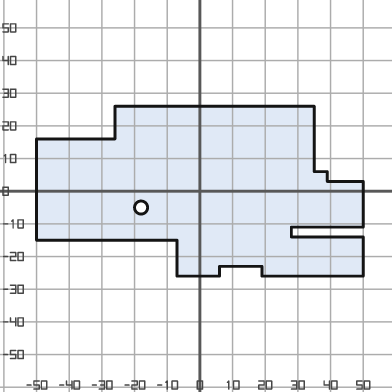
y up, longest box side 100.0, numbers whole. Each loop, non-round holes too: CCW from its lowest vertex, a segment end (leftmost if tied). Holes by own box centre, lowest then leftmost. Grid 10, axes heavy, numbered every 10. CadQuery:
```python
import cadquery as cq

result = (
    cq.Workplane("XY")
    .moveTo(-7.0, -26.0)
    .lineTo(6.0, -26.0)
    .lineTo(6.0, -23.0)
    .lineTo(19.0, -23.0)
    .lineTo(19.0, -26.0)
    .lineTo(50.0, -26.0)
    .lineTo(50.0, -14.0)
    .lineTo(28.0, -14.0)
    .lineTo(28.0, -11.0)
    .lineTo(50.0, -11.0)
    .lineTo(50.0, 3.0)
    .lineTo(39.0, 3.0)
    .lineTo(39.0, 6.0)
    .lineTo(35.0, 6.0)
    .lineTo(35.0, 26.0)
    .lineTo(-26.0, 26.0)
    .lineTo(-26.0, 16.0)
    .lineTo(-50.0, 16.0)
    .lineTo(-50.0, -15.0)
    .lineTo(-7.0, -15.0)
    .close()
    .moveTo(-18.0, -5.0)
    .circle(2.0)
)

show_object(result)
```